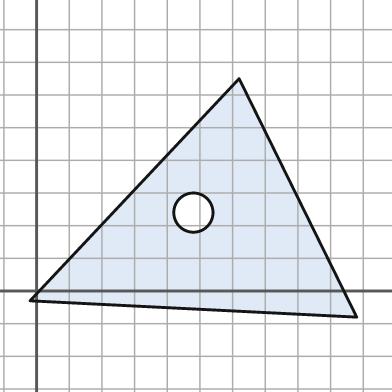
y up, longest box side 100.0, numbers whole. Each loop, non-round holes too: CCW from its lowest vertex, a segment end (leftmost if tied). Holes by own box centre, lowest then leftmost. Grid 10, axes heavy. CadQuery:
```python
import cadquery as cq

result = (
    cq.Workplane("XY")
    .moveTo(98.0, -8.0)
    .lineTo(62.0, 65.0)
    .lineTo(-2.0, -3.0)
    .close()
    .moveTo(48.0, 24.0)
    .circle(6.0)
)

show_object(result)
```